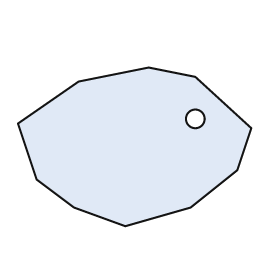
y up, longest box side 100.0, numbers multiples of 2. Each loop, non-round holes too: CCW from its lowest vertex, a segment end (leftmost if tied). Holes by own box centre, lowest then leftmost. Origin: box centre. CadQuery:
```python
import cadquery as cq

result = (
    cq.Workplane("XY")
    .moveTo(-4.0, -34.0)
    .lineTo(24.0, -26.0)
    .lineTo(44.0, -10.0)
    .lineTo(50.0, 8.0)
    .lineTo(26.0, 30.0)
    .lineTo(6.0, 34.0)
    .lineTo(-24.0, 28.0)
    .lineTo(-50.0, 10.0)
    .lineTo(-42.0, -14.0)
    .lineTo(-26.0, -26.0)
    .close()
    .moveTo(26.0, 12.0)
    .circle(4.0)
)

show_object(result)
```